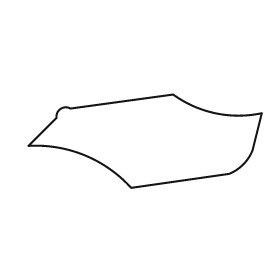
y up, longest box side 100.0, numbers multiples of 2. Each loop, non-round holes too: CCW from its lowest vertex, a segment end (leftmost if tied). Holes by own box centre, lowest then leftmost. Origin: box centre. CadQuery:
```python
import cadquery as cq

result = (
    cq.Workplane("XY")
    .moveTo(-6.0, -20.0)
    .lineTo(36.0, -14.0)
    .threePointArc((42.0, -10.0), (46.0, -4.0))
    .lineTo(50.0, 12.0)
    .threePointArc((30.0, 12.0), (12.0, 20.0))
    .lineTo(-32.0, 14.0)
    .threePointArc((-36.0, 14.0), (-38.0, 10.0))
    .lineTo(-50.0, -2.0)
    .threePointArc((-26.0, -6.0), (-6.0, -20.0))
    .close()
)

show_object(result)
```